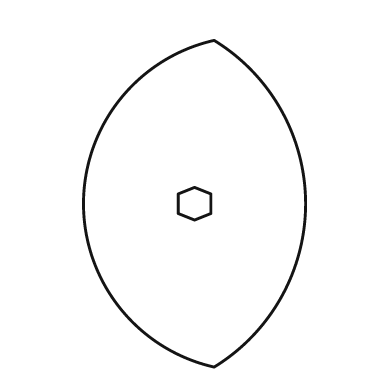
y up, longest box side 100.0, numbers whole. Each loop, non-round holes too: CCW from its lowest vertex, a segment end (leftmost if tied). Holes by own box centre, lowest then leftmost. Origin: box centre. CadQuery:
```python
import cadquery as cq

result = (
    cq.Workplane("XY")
    .moveTo(6.0, -50.0)
    .threePointArc((34.0, 0.0), (6.0, 50.0))
    .threePointArc((-34.0, 0.0), (6.0, -50.0))
    .close()
    .moveTo(0.0, -5.0)
    .lineTo(5.0, -3.0)
    .lineTo(5.0, 3.0)
    .lineTo(0.0, 5.0)
    .lineTo(-5.0, 3.0)
    .lineTo(-5.0, -3.0)
    .close()
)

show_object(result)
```